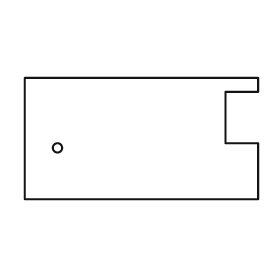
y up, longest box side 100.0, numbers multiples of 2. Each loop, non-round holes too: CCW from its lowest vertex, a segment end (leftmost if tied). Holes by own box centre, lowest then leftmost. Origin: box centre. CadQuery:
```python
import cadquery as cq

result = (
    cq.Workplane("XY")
    .moveTo(-50.0, -26.0)
    .lineTo(50.0, -26.0)
    .lineTo(50.0, -2.0)
    .lineTo(36.0, -2.0)
    .lineTo(36.0, 20.0)
    .lineTo(50.0, 20.0)
    .lineTo(50.0, 26.0)
    .lineTo(-50.0, 26.0)
    .close()
    .moveTo(-36.0, -4.0)
    .circle(2.0)
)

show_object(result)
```